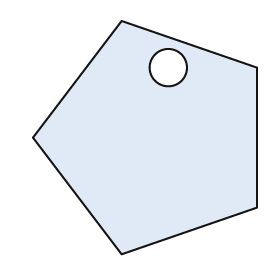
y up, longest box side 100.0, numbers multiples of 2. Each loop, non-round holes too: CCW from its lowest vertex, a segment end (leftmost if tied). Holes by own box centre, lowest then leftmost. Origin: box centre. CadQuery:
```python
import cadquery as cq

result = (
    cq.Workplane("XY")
    .moveTo(-10.0, -50.0)
    .lineTo(48.0, -30.0)
    .lineTo(48.0, 30.0)
    .lineTo(-10.0, 50.0)
    .lineTo(-48.0, 0.0)
    .close()
    .moveTo(10.0, 30.0)
    .circle(8.0)
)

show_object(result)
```